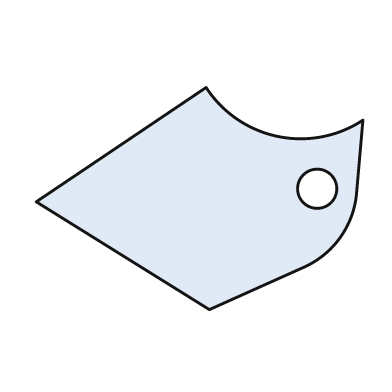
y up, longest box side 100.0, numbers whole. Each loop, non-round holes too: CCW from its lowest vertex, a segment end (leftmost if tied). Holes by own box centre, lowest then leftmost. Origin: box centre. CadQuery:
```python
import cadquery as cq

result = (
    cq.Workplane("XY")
    .moveTo(3.0, -34.0)
    .lineTo(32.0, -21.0)
    .threePointArc((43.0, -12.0), (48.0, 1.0))
    .lineTo(50.0, 24.0)
    .threePointArc((24.0, 19.0), (2.0, 34.0))
    .lineTo(-50.0, -1.0)
    .close()
    .moveTo(36.0, 3.0)
    .circle(6.0)
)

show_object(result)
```